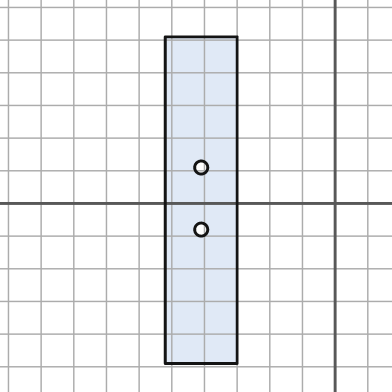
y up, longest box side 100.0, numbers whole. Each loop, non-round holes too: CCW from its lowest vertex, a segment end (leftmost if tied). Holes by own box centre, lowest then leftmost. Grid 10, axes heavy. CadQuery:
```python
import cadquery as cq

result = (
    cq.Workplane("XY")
    .moveTo(-52.0, -49.0)
    .lineTo(-30.0, -49.0)
    .lineTo(-30.0, 51.0)
    .lineTo(-52.0, 51.0)
    .close()
    .moveTo(-41.0, -8.0)
    .circle(2.0)
    .moveTo(-41.0, 11.0)
    .circle(2.0)
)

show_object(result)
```